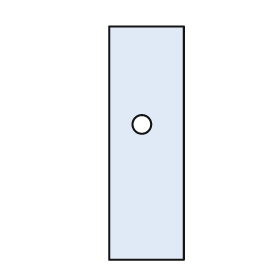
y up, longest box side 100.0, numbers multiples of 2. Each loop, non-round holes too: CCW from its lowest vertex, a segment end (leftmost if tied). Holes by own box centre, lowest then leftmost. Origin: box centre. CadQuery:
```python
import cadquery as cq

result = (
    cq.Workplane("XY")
    .moveTo(-16.0, -50.0)
    .lineTo(16.0, -50.0)
    .lineTo(16.0, 50.0)
    .lineTo(-16.0, 50.0)
    .close()
    .moveTo(-2.0, 8.0)
    .circle(4.0)
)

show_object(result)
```